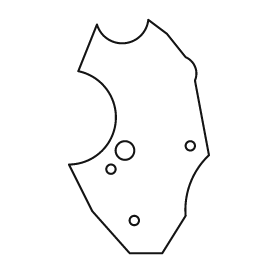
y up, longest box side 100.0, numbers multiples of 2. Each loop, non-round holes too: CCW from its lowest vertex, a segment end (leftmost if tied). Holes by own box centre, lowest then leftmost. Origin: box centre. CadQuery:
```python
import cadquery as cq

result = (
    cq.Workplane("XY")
    .moveTo(-4.0, -50.0)
    .lineTo(10.0, -50.0)
    .lineTo(20.0, -34.0)
    .threePointArc((22.0, -20.0), (30.0, -8.0))
    .lineTo(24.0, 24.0)
    .threePointArc((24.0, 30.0), (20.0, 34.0))
    .lineTo(12.0, 44.0)
    .lineTo(4.0, 50.0)
    .threePointArc((-6.0, 40.0), (-18.0, 48.0))
    .lineTo(-26.0, 28.0)
    .threePointArc((-10.0, 6.0), (-30.0, -12.0))
    .lineTo(-20.0, -32.0)
    .close()
    .moveTo(-2.0, -36.0)
    .circle(2.0)
    .moveTo(-12.0, -14.0)
    .circle(2.0)
    .moveTo(-6.0, -6.0)
    .circle(4.0)
    .moveTo(22.0, -4.0)
    .circle(2.0)
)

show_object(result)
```